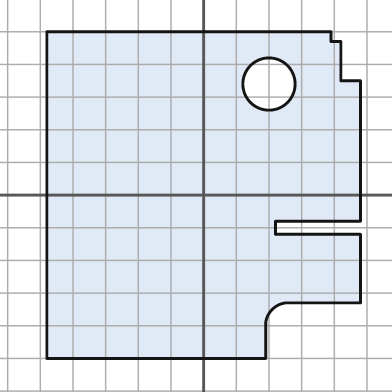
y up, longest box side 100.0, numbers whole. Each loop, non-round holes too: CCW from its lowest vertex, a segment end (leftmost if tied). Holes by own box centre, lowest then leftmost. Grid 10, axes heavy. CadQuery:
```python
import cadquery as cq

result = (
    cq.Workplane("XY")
    .moveTo(-48.0, -50.0)
    .lineTo(19.0, -50.0)
    .lineTo(19.0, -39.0)
    .threePointArc((21.0, -35.0), (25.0, -33.0))
    .lineTo(48.0, -33.0)
    .lineTo(48.0, -12.0)
    .lineTo(22.0, -12.0)
    .lineTo(22.0, -8.0)
    .lineTo(48.0, -8.0)
    .lineTo(48.0, 35.0)
    .lineTo(42.0, 35.0)
    .lineTo(42.0, 47.0)
    .lineTo(39.0, 47.0)
    .lineTo(39.0, 50.0)
    .lineTo(-48.0, 50.0)
    .close()
    .moveTo(20.0, 34.0)
    .circle(8.0)
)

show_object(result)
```